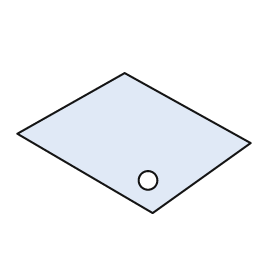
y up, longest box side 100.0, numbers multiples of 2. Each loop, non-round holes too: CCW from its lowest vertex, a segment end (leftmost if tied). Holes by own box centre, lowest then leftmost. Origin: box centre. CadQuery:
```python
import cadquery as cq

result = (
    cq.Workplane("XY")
    .moveTo(8.0, -30.0)
    .lineTo(50.0, 0.0)
    .lineTo(-4.0, 30.0)
    .lineTo(-50.0, 4.0)
    .close()
    .moveTo(6.0, -16.0)
    .circle(4.0)
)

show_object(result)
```